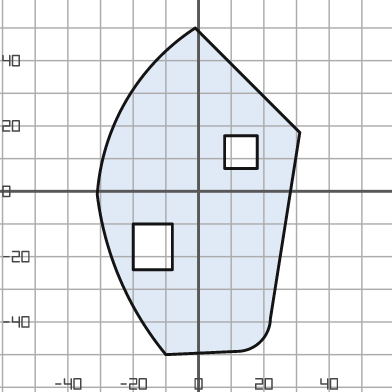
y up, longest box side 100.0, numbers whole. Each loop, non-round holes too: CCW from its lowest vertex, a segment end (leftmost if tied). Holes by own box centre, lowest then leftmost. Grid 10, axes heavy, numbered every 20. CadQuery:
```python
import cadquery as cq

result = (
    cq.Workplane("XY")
    .moveTo(-10.0, -50.0)
    .lineTo(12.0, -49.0)
    .threePointArc((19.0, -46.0), (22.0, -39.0))
    .lineTo(31.0, 18.0)
    .lineTo(-1.0, 50.0)
    .threePointArc((-22.0, 28.0), (-31.0, -1.0))
    .threePointArc((-24.0, -27.0), (-10.0, -50.0))
    .close()
    .moveTo(-20.0, -24.0)
    .lineTo(-8.0, -24.0)
    .lineTo(-8.0, -10.0)
    .lineTo(-20.0, -10.0)
    .close()
    .moveTo(8.0, 7.0)
    .lineTo(18.0, 7.0)
    .lineTo(18.0, 17.0)
    .lineTo(8.0, 17.0)
    .close()
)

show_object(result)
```